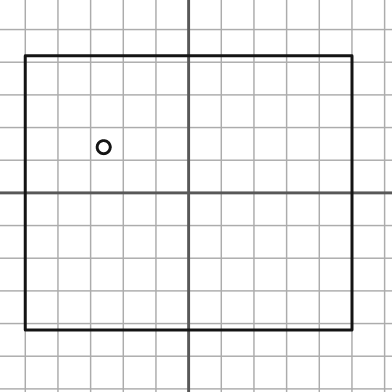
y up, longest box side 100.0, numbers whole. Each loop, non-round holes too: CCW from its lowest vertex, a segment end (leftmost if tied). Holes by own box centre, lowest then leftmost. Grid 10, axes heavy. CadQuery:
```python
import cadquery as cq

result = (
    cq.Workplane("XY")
    .moveTo(-50.0, -42.0)
    .lineTo(50.0, -42.0)
    .lineTo(50.0, 42.0)
    .lineTo(-50.0, 42.0)
    .close()
    .moveTo(-26.0, 14.0)
    .circle(2.0)
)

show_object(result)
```